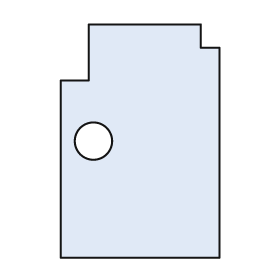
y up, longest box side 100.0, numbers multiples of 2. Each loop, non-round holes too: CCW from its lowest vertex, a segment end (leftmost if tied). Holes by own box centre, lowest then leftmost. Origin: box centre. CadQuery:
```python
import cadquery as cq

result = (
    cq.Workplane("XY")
    .moveTo(-34.0, -50.0)
    .lineTo(34.0, -50.0)
    .lineTo(34.0, 40.0)
    .lineTo(26.0, 40.0)
    .lineTo(26.0, 50.0)
    .lineTo(-22.0, 50.0)
    .lineTo(-22.0, 26.0)
    .lineTo(-34.0, 26.0)
    .close()
    .moveTo(-20.0, 0.0)
    .circle(8.0)
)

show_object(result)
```